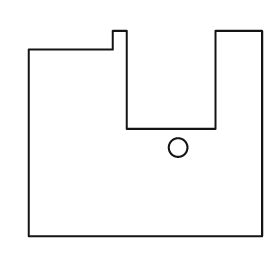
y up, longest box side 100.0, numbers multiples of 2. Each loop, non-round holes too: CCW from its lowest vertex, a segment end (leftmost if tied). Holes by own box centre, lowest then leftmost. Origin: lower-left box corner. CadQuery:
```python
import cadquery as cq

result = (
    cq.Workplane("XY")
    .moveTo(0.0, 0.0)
    .lineTo(100.0, 0.0)
    .lineTo(100.0, 88.0)
    .lineTo(80.0, 88.0)
    .lineTo(80.0, 46.0)
    .lineTo(42.0, 46.0)
    .lineTo(42.0, 88.0)
    .lineTo(36.0, 88.0)
    .lineTo(36.0, 80.0)
    .lineTo(0.0, 80.0)
    .close()
    .moveTo(64.0, 38.0)
    .circle(4.0)
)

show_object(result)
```